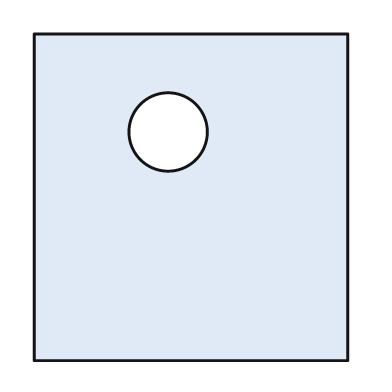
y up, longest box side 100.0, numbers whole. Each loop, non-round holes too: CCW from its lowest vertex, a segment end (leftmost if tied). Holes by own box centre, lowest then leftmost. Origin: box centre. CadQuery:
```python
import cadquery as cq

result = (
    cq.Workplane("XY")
    .moveTo(-48.0, -50.0)
    .lineTo(48.0, -50.0)
    .lineTo(48.0, 50.0)
    .lineTo(-48.0, 50.0)
    .close()
    .moveTo(-7.0, 20.0)
    .circle(12.0)
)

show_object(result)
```